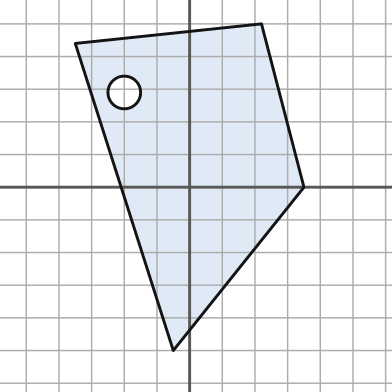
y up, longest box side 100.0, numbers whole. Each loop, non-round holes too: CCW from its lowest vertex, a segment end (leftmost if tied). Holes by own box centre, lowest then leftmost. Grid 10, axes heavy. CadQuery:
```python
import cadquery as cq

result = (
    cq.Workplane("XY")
    .moveTo(-5.0, -50.0)
    .lineTo(35.0, 0.0)
    .lineTo(22.0, 50.0)
    .lineTo(-35.0, 44.0)
    .close()
    .moveTo(-20.0, 29.0)
    .circle(5.0)
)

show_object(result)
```